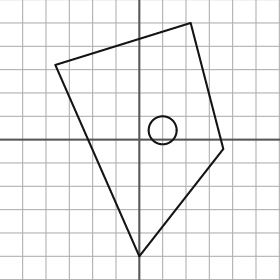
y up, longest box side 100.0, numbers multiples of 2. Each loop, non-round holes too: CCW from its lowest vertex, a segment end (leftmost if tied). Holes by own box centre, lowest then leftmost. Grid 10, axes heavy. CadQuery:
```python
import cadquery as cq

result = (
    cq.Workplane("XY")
    .moveTo(0.0, -50.0)
    .lineTo(36.0, -4.0)
    .lineTo(22.0, 50.0)
    .lineTo(-36.0, 32.0)
    .close()
    .moveTo(10.0, 4.0)
    .circle(6.0)
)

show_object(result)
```